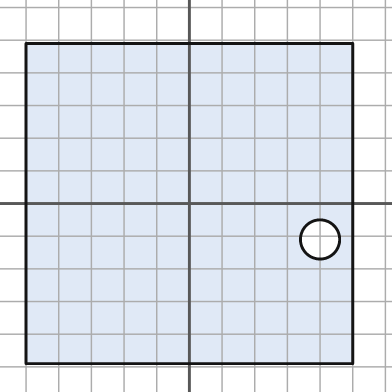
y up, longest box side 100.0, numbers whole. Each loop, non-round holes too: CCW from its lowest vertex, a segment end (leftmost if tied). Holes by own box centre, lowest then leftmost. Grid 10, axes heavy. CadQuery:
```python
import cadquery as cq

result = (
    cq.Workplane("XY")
    .moveTo(-50.0, -49.0)
    .lineTo(50.0, -49.0)
    .lineTo(50.0, 49.0)
    .lineTo(-50.0, 49.0)
    .close()
    .moveTo(40.0, -11.0)
    .circle(6.0)
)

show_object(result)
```